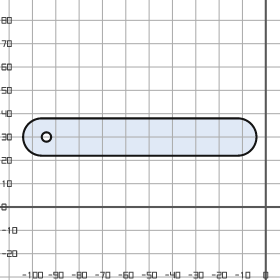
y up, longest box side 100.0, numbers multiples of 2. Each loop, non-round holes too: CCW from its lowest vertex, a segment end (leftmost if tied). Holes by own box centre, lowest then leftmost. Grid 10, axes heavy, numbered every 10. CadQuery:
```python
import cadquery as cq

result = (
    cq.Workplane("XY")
    .moveTo(-96.0, 22.0)
    .lineTo(-12.0, 22.0)
    .threePointArc((-4.0, 30.0), (-12.0, 38.0))
    .lineTo(-96.0, 38.0)
    .threePointArc((-104.0, 30.0), (-96.0, 22.0))
    .close()
    .moveTo(-94.0, 30.0)
    .circle(2.0)
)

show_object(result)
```